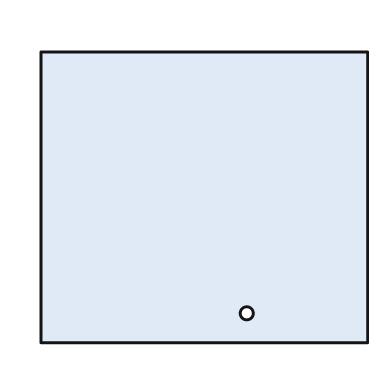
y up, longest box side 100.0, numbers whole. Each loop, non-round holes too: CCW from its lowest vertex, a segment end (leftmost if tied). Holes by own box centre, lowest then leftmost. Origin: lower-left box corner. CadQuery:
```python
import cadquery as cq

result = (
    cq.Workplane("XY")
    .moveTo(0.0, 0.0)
    .lineTo(100.0, 0.0)
    .lineTo(100.0, 89.0)
    .lineTo(0.0, 89.0)
    .close()
    .moveTo(63.0, 9.0)
    .circle(2.0)
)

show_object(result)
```